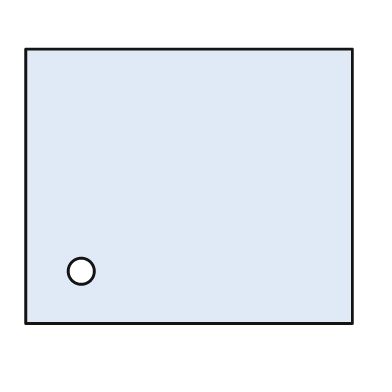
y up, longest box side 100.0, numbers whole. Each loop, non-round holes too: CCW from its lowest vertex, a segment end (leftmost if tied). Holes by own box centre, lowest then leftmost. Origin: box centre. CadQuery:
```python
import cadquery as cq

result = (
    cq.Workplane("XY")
    .moveTo(-50.0, -42.0)
    .lineTo(50.0, -42.0)
    .lineTo(50.0, 42.0)
    .lineTo(-50.0, 42.0)
    .close()
    .moveTo(-33.0, -26.0)
    .circle(4.0)
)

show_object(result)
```